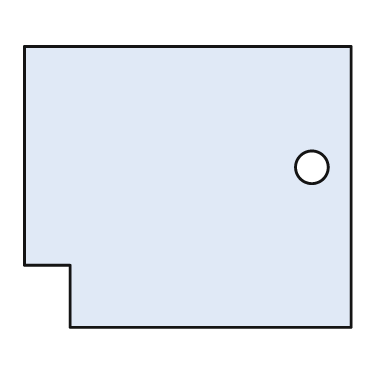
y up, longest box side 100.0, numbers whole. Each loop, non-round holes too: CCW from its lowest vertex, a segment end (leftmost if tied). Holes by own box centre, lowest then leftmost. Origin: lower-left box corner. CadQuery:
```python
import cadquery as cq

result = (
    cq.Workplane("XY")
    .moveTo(14.0, 0.0)
    .lineTo(100.0, 0.0)
    .lineTo(100.0, 86.0)
    .lineTo(0.0, 86.0)
    .lineTo(0.0, 19.0)
    .lineTo(14.0, 19.0)
    .close()
    .moveTo(88.0, 49.0)
    .circle(5.0)
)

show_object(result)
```